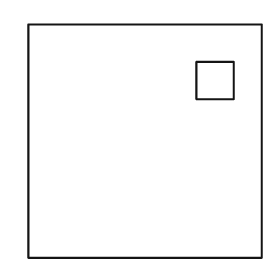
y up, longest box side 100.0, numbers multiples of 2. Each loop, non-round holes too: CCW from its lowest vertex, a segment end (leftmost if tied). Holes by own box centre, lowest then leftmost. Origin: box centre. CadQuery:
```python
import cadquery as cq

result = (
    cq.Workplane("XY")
    .moveTo(-50.0, -50.0)
    .lineTo(50.0, -50.0)
    .lineTo(50.0, 50.0)
    .lineTo(-50.0, 50.0)
    .close()
    .moveTo(22.0, 18.0)
    .lineTo(38.0, 18.0)
    .lineTo(38.0, 34.0)
    .lineTo(22.0, 34.0)
    .close()
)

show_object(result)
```